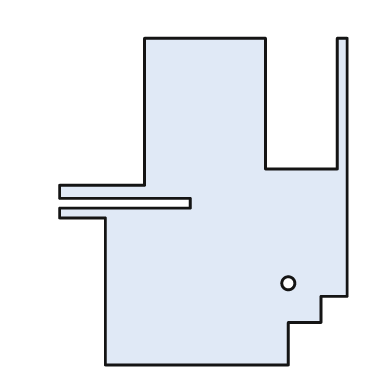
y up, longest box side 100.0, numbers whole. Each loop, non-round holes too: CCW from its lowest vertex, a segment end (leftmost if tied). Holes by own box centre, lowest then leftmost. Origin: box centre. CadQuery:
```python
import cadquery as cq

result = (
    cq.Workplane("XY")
    .moveTo(-30.0, -50.0)
    .lineTo(26.0, -50.0)
    .lineTo(26.0, -37.0)
    .lineTo(36.0, -37.0)
    .lineTo(36.0, -29.0)
    .lineTo(44.0, -29.0)
    .lineTo(44.0, 50.0)
    .lineTo(41.0, 50.0)
    .lineTo(41.0, 10.0)
    .lineTo(19.0, 10.0)
    .lineTo(19.0, 50.0)
    .lineTo(-18.0, 50.0)
    .lineTo(-18.0, 5.0)
    .lineTo(-44.0, 5.0)
    .lineTo(-44.0, 1.0)
    .lineTo(-4.0, 1.0)
    .lineTo(-4.0, -2.0)
    .lineTo(-44.0, -2.0)
    .lineTo(-44.0, -5.0)
    .lineTo(-30.0, -5.0)
    .close()
    .moveTo(26.0, -25.0)
    .circle(2.0)
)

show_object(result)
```